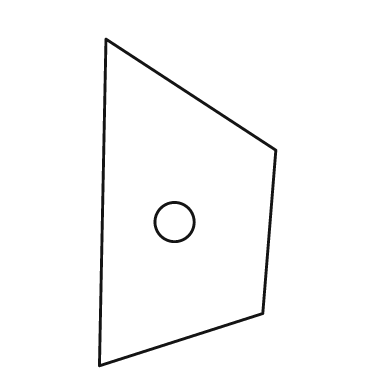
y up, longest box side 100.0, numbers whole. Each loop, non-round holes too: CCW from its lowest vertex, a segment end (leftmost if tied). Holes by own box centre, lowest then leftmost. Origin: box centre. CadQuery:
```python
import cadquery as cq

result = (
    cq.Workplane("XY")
    .moveTo(-27.0, -50.0)
    .lineTo(23.0, -34.0)
    .lineTo(27.0, 16.0)
    .lineTo(-25.0, 50.0)
    .close()
    .moveTo(-4.0, -6.0)
    .circle(6.0)
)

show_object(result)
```